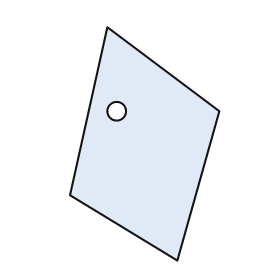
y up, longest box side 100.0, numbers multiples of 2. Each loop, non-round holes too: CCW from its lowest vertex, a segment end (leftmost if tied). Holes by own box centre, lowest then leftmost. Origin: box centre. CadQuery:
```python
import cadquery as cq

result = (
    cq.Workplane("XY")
    .moveTo(14.0, -50.0)
    .lineTo(32.0, 14.0)
    .lineTo(-16.0, 50.0)
    .lineTo(-32.0, -22.0)
    .close()
    .moveTo(-12.0, 14.0)
    .circle(4.0)
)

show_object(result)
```